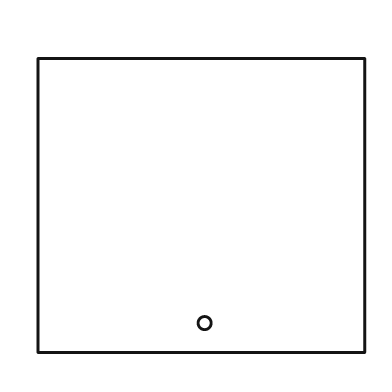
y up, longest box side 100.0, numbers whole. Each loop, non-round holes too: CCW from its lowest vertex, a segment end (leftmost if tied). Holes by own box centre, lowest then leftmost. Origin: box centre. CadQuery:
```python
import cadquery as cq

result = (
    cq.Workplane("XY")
    .moveTo(-50.0, -45.0)
    .lineTo(50.0, -45.0)
    .lineTo(50.0, 45.0)
    .lineTo(-50.0, 45.0)
    .close()
    .moveTo(1.0, -36.0)
    .circle(2.0)
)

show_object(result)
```